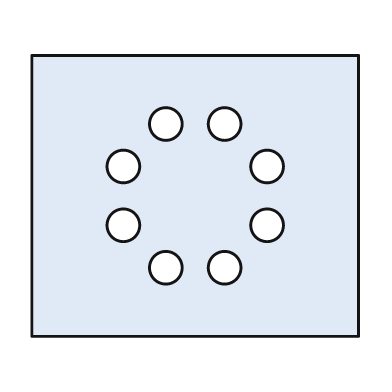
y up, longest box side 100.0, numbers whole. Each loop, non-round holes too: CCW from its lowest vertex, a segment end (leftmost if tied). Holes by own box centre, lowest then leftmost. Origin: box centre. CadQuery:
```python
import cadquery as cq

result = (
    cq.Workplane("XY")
    .moveTo(-50.0, -43.0)
    .lineTo(50.0, -43.0)
    .lineTo(50.0, 43.0)
    .lineTo(-50.0, 43.0)
    .close()
    .moveTo(-9.0, -22.0)
    .circle(5.0)
    .moveTo(9.0, -22.0)
    .circle(5.0)
    .moveTo(-22.0, -9.0)
    .circle(5.0)
    .moveTo(22.0, -9.0)
    .circle(5.0)
    .moveTo(-22.0, 9.0)
    .circle(5.0)
    .moveTo(22.0, 9.0)
    .circle(5.0)
    .moveTo(-9.0, 22.0)
    .circle(5.0)
    .moveTo(9.0, 22.0)
    .circle(5.0)
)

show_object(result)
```